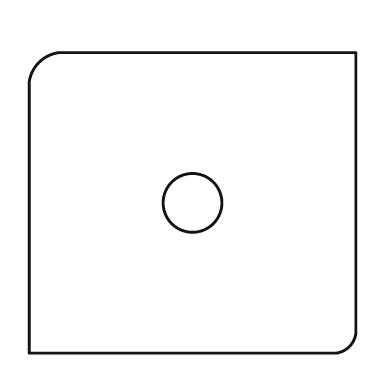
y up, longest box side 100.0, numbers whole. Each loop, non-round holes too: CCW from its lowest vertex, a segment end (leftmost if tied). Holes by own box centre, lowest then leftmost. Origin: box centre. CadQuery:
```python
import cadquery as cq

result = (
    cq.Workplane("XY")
    .moveTo(-50.0, -46.0)
    .lineTo(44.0, -46.0)
    .threePointArc((48.0, -44.0), (50.0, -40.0))
    .lineTo(50.0, 46.0)
    .lineTo(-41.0, 46.0)
    .threePointArc((-47.0, 43.0), (-50.0, 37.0))
    .close()
    .moveTo(0.0, 0.0)
    .circle(9.0)
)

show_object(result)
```